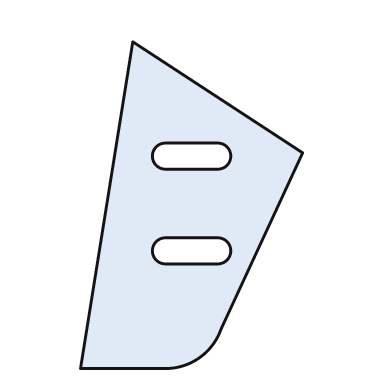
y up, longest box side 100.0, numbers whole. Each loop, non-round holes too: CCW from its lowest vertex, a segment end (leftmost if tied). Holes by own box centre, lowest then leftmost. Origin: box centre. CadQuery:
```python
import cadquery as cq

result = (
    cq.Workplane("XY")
    .moveTo(-34.0, -50.0)
    .lineTo(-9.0, -50.0)
    .threePointArc((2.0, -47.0), (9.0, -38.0))
    .lineTo(34.0, 16.0)
    .lineTo(-18.0, 50.0)
    .close()
    .moveTo(-8.0, -18.0)
    .lineTo(8.0, -18.0)
    .threePointArc((12.0, -14.0), (8.0, -10.0))
    .lineTo(-8.0, -10.0)
    .threePointArc((-12.0, -14.0), (-8.0, -18.0))
    .close()
    .moveTo(-8.0, 11.0)
    .lineTo(8.0, 11.0)
    .threePointArc((12.0, 15.0), (8.0, 19.0))
    .lineTo(-8.0, 19.0)
    .threePointArc((-12.0, 15.0), (-8.0, 11.0))
    .close()
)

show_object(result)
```